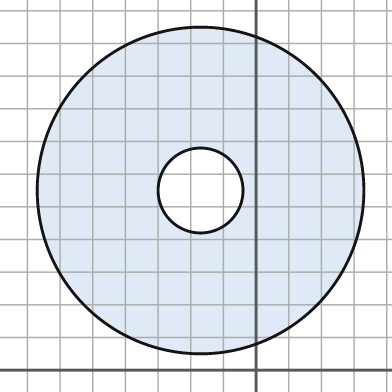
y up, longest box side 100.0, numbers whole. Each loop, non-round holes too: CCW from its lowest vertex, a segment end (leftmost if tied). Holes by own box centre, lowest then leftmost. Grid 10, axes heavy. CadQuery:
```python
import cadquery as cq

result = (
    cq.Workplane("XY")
    .moveTo(-17.0, 55.0)
    .circle(50.0)
    .moveTo(-17.0, 55.0)
    .circle(13.0)
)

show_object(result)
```